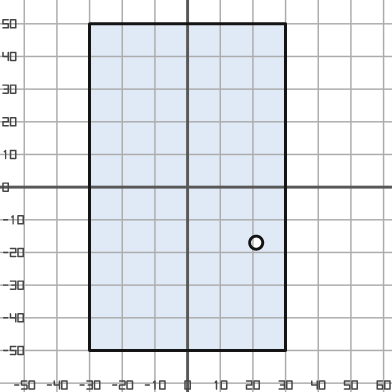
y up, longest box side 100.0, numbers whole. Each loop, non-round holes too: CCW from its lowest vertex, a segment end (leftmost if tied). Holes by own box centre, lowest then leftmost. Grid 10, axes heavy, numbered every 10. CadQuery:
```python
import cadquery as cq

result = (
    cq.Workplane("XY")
    .moveTo(-30.0, -50.0)
    .lineTo(30.0, -50.0)
    .lineTo(30.0, 50.0)
    .lineTo(-30.0, 50.0)
    .close()
    .moveTo(21.0, -17.0)
    .circle(2.0)
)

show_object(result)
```